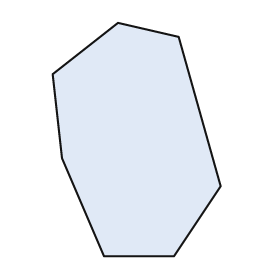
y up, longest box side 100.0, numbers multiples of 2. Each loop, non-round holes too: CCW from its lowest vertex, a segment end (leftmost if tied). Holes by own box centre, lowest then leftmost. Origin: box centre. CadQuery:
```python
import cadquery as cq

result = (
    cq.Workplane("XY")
    .moveTo(-14.0, -50.0)
    .lineTo(16.0, -50.0)
    .lineTo(36.0, -20.0)
    .lineTo(18.0, 44.0)
    .lineTo(-8.0, 50.0)
    .lineTo(-36.0, 28.0)
    .lineTo(-32.0, -8.0)
    .close()
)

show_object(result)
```